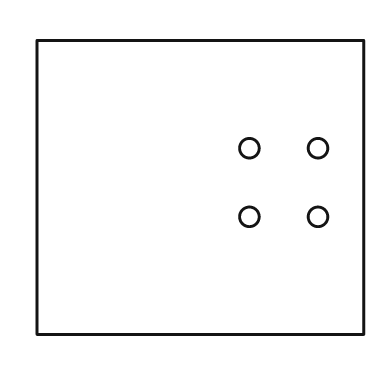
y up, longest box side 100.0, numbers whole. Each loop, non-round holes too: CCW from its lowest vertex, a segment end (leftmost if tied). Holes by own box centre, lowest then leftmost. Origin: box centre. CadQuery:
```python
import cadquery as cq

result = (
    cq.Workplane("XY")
    .moveTo(-50.0, -45.0)
    .lineTo(50.0, -45.0)
    .lineTo(50.0, 45.0)
    .lineTo(-50.0, 45.0)
    .close()
    .moveTo(15.0, -9.0)
    .circle(3.0)
    .moveTo(36.0, -9.0)
    .circle(3.0)
    .moveTo(15.0, 12.0)
    .circle(3.0)
    .moveTo(36.0, 12.0)
    .circle(3.0)
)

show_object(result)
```